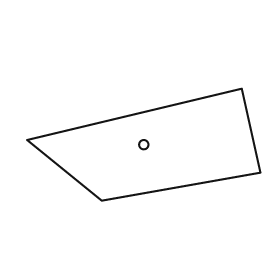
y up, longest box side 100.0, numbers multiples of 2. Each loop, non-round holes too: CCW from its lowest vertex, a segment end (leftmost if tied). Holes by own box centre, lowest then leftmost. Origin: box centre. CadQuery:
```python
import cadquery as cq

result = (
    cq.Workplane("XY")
    .moveTo(-18.0, -24.0)
    .lineTo(50.0, -12.0)
    .lineTo(42.0, 24.0)
    .lineTo(-50.0, 2.0)
    .close()
    .moveTo(0.0, 0.0)
    .circle(2.0)
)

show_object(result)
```